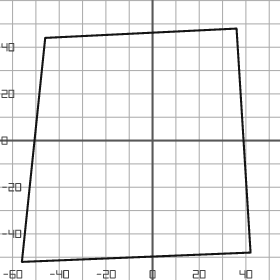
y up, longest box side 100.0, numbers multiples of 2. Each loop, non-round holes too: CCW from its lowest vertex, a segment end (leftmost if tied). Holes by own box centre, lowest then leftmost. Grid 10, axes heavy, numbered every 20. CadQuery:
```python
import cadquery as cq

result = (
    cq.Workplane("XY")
    .moveTo(-56.0, -52.0)
    .lineTo(42.0, -48.0)
    .lineTo(36.0, 48.0)
    .lineTo(-46.0, 44.0)
    .close()
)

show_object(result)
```